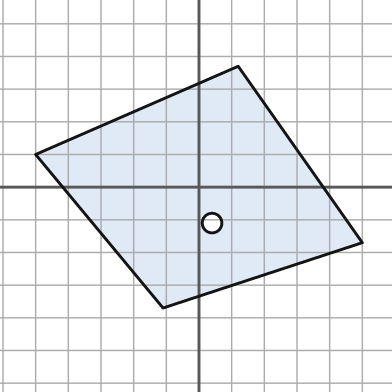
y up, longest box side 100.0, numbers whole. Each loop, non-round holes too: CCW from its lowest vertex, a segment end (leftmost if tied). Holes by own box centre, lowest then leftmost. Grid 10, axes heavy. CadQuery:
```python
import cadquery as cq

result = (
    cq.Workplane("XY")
    .moveTo(-11.0, -37.0)
    .lineTo(50.0, -17.0)
    .lineTo(12.0, 37.0)
    .lineTo(-50.0, 10.0)
    .close()
    .moveTo(4.0, -11.0)
    .circle(3.0)
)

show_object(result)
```